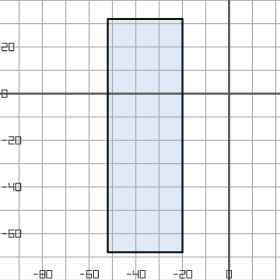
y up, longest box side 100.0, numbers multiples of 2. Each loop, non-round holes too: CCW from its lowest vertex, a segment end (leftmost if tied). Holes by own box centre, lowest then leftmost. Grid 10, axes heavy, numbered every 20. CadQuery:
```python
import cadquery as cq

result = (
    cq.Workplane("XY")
    .moveTo(-52.0, -68.0)
    .lineTo(-20.0, -68.0)
    .lineTo(-20.0, 32.0)
    .lineTo(-52.0, 32.0)
    .close()
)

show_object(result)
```